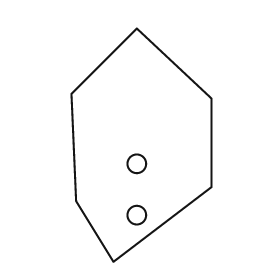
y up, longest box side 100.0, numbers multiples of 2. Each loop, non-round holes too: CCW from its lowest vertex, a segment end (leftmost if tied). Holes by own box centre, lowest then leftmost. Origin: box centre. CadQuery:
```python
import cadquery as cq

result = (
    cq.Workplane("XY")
    .moveTo(-12.0, -50.0)
    .lineTo(30.0, -18.0)
    .lineTo(30.0, 20.0)
    .lineTo(-2.0, 50.0)
    .lineTo(-30.0, 22.0)
    .lineTo(-28.0, -24.0)
    .close()
    .moveTo(-2.0, -30.0)
    .circle(4.0)
    .moveTo(-2.0, -8.0)
    .circle(4.0)
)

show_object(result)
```